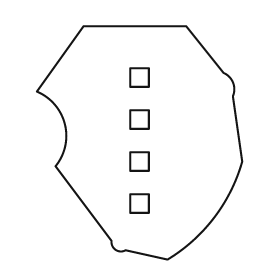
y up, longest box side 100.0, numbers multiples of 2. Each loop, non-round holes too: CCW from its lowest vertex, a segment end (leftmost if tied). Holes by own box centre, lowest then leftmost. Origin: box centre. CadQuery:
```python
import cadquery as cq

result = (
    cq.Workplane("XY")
    .moveTo(12.0, -50.0)
    .threePointArc((32.0, -32.0), (44.0, -8.0))
    .lineTo(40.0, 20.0)
    .threePointArc((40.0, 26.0), (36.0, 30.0))
    .lineTo(20.0, 50.0)
    .lineTo(-24.0, 50.0)
    .lineTo(-44.0, 22.0)
    .threePointArc((-32.0, 8.0), (-36.0, -10.0))
    .lineTo(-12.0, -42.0)
    .threePointArc((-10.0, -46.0), (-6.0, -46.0))
    .close()
    .moveTo(-4.0, -30.0)
    .lineTo(4.0, -30.0)
    .lineTo(4.0, -22.0)
    .lineTo(-4.0, -22.0)
    .close()
    .moveTo(-4.0, -12.0)
    .lineTo(4.0, -12.0)
    .lineTo(4.0, -4.0)
    .lineTo(-4.0, -4.0)
    .close()
    .moveTo(-4.0, 6.0)
    .lineTo(4.0, 6.0)
    .lineTo(4.0, 14.0)
    .lineTo(-4.0, 14.0)
    .close()
    .moveTo(-4.0, 24.0)
    .lineTo(4.0, 24.0)
    .lineTo(4.0, 32.0)
    .lineTo(-4.0, 32.0)
    .close()
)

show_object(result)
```